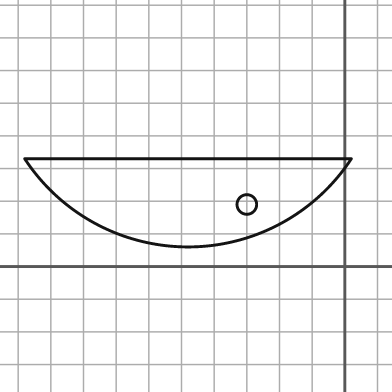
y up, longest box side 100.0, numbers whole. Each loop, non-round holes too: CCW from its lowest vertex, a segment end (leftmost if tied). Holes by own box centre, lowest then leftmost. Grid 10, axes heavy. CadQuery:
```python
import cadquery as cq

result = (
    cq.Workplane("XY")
    .moveTo(-98.0, 33.0)
    .threePointArc((-48.0, 6.0), (2.0, 33.0))
    .close()
    .moveTo(-30.0, 19.0)
    .circle(3.0)
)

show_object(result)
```